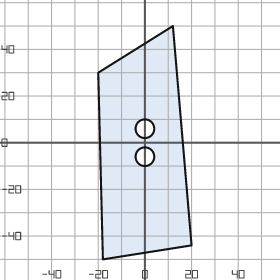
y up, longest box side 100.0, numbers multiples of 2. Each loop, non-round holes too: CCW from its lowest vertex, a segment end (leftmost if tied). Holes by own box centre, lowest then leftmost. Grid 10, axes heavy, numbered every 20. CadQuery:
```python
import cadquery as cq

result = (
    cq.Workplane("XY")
    .moveTo(-18.0, -50.0)
    .lineTo(20.0, -44.0)
    .lineTo(12.0, 50.0)
    .lineTo(-20.0, 30.0)
    .close()
    .moveTo(0.0, -6.0)
    .circle(4.0)
    .moveTo(0.0, 6.0)
    .circle(4.0)
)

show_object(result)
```